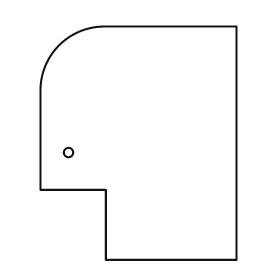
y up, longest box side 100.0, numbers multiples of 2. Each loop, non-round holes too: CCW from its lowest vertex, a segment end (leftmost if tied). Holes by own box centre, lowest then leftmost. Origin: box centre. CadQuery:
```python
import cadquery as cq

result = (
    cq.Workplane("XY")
    .moveTo(-14.0, -50.0)
    .lineTo(42.0, -50.0)
    .lineTo(42.0, 50.0)
    .lineTo(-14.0, 50.0)
    .threePointArc((-34.0, 42.0), (-42.0, 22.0))
    .lineTo(-42.0, -20.0)
    .lineTo(-14.0, -20.0)
    .close()
    .moveTo(-30.0, -4.0)
    .circle(2.0)
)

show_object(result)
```